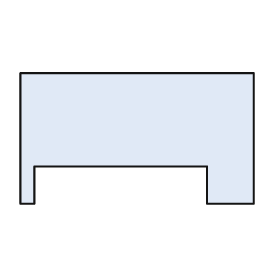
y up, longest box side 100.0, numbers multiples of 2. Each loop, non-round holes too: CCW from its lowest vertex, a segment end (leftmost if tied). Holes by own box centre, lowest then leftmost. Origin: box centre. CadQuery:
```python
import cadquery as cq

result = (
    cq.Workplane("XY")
    .moveTo(-50.0, -28.0)
    .lineTo(-44.0, -28.0)
    .lineTo(-44.0, -12.0)
    .lineTo(30.0, -12.0)
    .lineTo(30.0, -28.0)
    .lineTo(50.0, -28.0)
    .lineTo(50.0, 28.0)
    .lineTo(-50.0, 28.0)
    .close()
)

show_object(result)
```